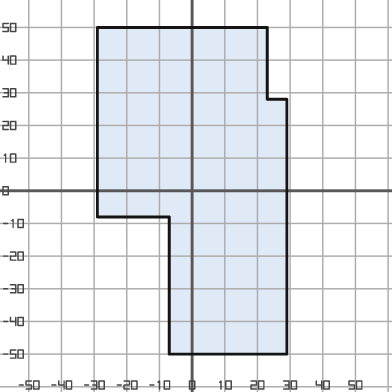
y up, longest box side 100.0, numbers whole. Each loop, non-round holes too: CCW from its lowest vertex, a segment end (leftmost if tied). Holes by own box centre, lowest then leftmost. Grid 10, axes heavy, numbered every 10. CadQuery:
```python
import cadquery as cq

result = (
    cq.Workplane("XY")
    .moveTo(-7.0, -50.0)
    .lineTo(29.0, -50.0)
    .lineTo(29.0, 28.0)
    .lineTo(23.0, 28.0)
    .lineTo(23.0, 50.0)
    .lineTo(-29.0, 50.0)
    .lineTo(-29.0, -8.0)
    .lineTo(-7.0, -8.0)
    .close()
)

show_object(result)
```